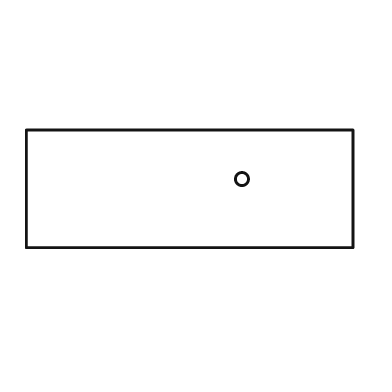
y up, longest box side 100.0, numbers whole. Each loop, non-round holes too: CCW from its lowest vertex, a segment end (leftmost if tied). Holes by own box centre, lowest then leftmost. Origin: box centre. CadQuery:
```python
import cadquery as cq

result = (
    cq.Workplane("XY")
    .moveTo(-50.0, -18.0)
    .lineTo(50.0, -18.0)
    .lineTo(50.0, 18.0)
    .lineTo(-50.0, 18.0)
    .close()
    .moveTo(16.0, 3.0)
    .circle(2.0)
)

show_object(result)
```